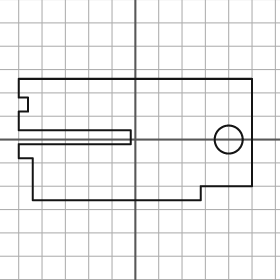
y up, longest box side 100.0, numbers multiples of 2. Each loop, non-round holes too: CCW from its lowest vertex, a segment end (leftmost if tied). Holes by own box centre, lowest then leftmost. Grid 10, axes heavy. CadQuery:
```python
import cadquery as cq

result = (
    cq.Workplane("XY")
    .moveTo(-44.0, -26.0)
    .lineTo(28.0, -26.0)
    .lineTo(28.0, -20.0)
    .lineTo(50.0, -20.0)
    .lineTo(50.0, 26.0)
    .lineTo(-50.0, 26.0)
    .lineTo(-50.0, 18.0)
    .lineTo(-46.0, 18.0)
    .lineTo(-46.0, 12.0)
    .lineTo(-50.0, 12.0)
    .lineTo(-50.0, 4.0)
    .lineTo(-2.0, 4.0)
    .lineTo(-2.0, -2.0)
    .lineTo(-50.0, -2.0)
    .lineTo(-50.0, -8.0)
    .lineTo(-44.0, -8.0)
    .close()
    .moveTo(40.0, 0.0)
    .circle(6.0)
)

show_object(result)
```